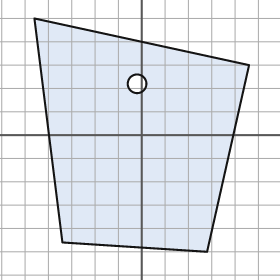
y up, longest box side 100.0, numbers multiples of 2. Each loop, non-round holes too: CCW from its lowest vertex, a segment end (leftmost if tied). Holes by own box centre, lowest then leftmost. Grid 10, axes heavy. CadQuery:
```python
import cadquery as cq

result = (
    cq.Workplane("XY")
    .moveTo(28.0, -50.0)
    .lineTo(46.0, 30.0)
    .lineTo(-46.0, 50.0)
    .lineTo(-34.0, -46.0)
    .close()
    .moveTo(-2.0, 22.0)
    .circle(4.0)
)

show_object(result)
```